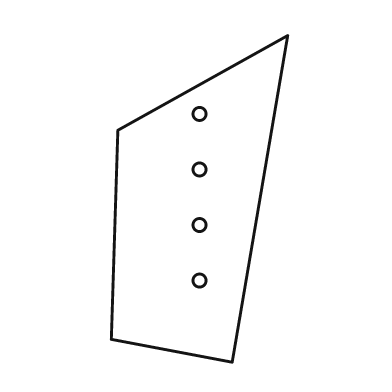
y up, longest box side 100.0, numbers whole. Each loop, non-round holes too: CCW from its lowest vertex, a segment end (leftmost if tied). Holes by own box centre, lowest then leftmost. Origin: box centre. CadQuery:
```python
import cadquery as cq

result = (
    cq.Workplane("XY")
    .moveTo(10.0, -50.0)
    .lineTo(27.0, 50.0)
    .lineTo(-25.0, 21.0)
    .lineTo(-27.0, -43.0)
    .close()
    .moveTo(0.0, -25.0)
    .circle(2.0)
    .moveTo(0.0, -8.0)
    .circle(2.0)
    .moveTo(0.0, 9.0)
    .circle(2.0)
    .moveTo(0.0, 26.0)
    .circle(2.0)
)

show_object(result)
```